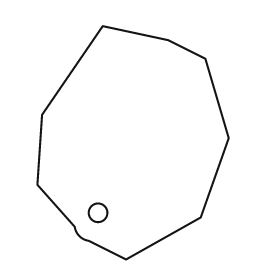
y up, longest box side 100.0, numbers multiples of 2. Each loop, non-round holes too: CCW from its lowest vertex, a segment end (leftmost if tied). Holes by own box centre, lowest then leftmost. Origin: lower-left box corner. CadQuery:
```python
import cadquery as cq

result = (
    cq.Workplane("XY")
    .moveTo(38.0, 0.0)
    .lineTo(70.0, 18.0)
    .lineTo(82.0, 52.0)
    .lineTo(72.0, 86.0)
    .lineTo(56.0, 94.0)
    .lineTo(28.0, 100.0)
    .lineTo(2.0, 62.0)
    .lineTo(0.0, 32.0)
    .lineTo(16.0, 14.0)
    .threePointArc((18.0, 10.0), (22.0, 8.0))
    .close()
    .moveTo(26.0, 20.0)
    .circle(4.0)
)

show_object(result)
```